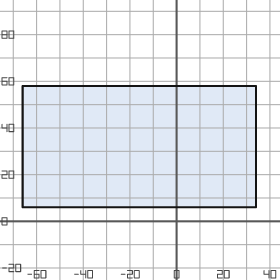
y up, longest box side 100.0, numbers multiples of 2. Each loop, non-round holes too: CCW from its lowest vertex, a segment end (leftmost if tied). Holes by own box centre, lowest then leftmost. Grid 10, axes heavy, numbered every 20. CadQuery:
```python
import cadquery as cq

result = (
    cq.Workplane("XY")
    .moveTo(-66.0, 6.0)
    .lineTo(34.0, 6.0)
    .lineTo(34.0, 58.0)
    .lineTo(-66.0, 58.0)
    .close()
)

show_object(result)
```